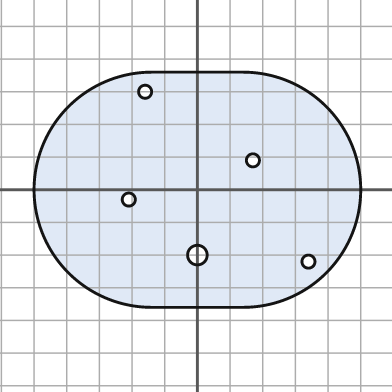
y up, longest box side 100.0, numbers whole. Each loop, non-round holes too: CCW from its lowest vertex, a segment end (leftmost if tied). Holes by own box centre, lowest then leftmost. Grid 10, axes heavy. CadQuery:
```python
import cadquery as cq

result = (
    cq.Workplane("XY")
    .moveTo(-14.0, -36.0)
    .lineTo(14.0, -36.0)
    .threePointArc((50.0, 0.0), (14.0, 36.0))
    .lineTo(-14.0, 36.0)
    .threePointArc((-50.0, 0.0), (-14.0, -36.0))
    .close()
    .moveTo(34.0, -22.0)
    .circle(2.0)
    .moveTo(0.0, -20.0)
    .circle(3.0)
    .moveTo(-21.0, -3.0)
    .circle(2.0)
    .moveTo(17.0, 9.0)
    .circle(2.0)
    .moveTo(-16.0, 30.0)
    .circle(2.0)
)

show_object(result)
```